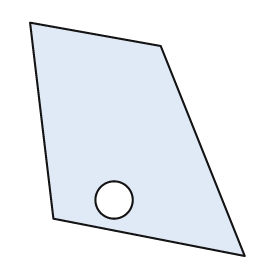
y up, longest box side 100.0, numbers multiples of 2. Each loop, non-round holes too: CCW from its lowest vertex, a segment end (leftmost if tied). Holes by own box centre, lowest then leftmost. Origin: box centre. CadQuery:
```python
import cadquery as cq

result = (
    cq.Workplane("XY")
    .moveTo(46.0, -50.0)
    .lineTo(10.0, 40.0)
    .lineTo(-46.0, 50.0)
    .lineTo(-36.0, -34.0)
    .close()
    .moveTo(-10.0, -26.0)
    .circle(8.0)
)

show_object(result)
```